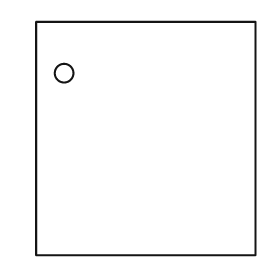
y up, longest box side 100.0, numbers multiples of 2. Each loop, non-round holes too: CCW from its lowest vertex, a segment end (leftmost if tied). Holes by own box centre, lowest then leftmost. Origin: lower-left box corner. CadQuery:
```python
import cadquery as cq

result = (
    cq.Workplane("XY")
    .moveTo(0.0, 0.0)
    .lineTo(94.0, 0.0)
    .lineTo(94.0, 100.0)
    .lineTo(0.0, 100.0)
    .close()
    .moveTo(12.0, 78.0)
    .circle(4.0)
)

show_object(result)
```